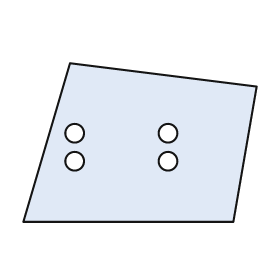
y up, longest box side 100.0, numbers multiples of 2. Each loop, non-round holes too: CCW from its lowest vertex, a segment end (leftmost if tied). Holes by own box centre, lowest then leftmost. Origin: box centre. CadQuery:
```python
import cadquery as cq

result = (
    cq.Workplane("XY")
    .moveTo(-50.0, -34.0)
    .lineTo(40.0, -34.0)
    .lineTo(50.0, 24.0)
    .lineTo(-30.0, 34.0)
    .close()
    .moveTo(-28.0, -8.0)
    .circle(4.0)
    .moveTo(12.0, -8.0)
    .circle(4.0)
    .moveTo(-28.0, 4.0)
    .circle(4.0)
    .moveTo(12.0, 4.0)
    .circle(4.0)
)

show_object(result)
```